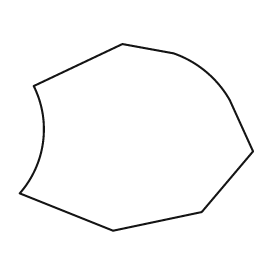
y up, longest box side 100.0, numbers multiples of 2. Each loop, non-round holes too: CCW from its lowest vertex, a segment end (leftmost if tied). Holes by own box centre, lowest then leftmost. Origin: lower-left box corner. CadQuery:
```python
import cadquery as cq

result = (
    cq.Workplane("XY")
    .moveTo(40.0, 0.0)
    .lineTo(78.0, 8.0)
    .lineTo(100.0, 34.0)
    .lineTo(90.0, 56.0)
    .threePointArc((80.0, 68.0), (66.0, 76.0))
    .lineTo(44.0, 80.0)
    .lineTo(6.0, 62.0)
    .threePointArc((10.0, 38.0), (0.0, 16.0))
    .close()
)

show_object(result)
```